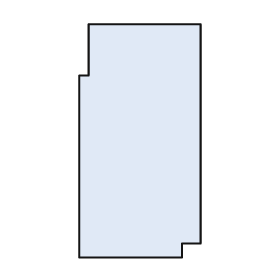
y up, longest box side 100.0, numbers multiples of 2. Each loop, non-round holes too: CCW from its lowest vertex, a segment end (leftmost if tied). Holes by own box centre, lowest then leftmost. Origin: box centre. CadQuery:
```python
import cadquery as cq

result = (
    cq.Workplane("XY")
    .moveTo(-26.0, -50.0)
    .lineTo(18.0, -50.0)
    .lineTo(18.0, -44.0)
    .lineTo(26.0, -44.0)
    .lineTo(26.0, 50.0)
    .lineTo(-22.0, 50.0)
    .lineTo(-22.0, 28.0)
    .lineTo(-26.0, 28.0)
    .close()
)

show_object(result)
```